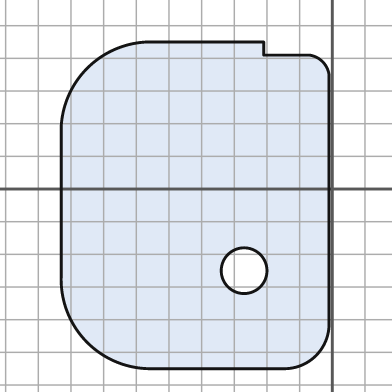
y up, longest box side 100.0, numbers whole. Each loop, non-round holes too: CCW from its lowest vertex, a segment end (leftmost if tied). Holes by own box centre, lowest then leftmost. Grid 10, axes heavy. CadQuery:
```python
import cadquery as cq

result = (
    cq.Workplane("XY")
    .moveTo(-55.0, -55.0)
    .lineTo(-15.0, -55.0)
    .threePointArc((-5.0, -51.0), (-1.0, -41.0))
    .lineTo(-1.0, 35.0)
    .threePointArc((-3.0, 39.0), (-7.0, 41.0))
    .lineTo(-21.0, 41.0)
    .lineTo(-21.0, 45.0)
    .lineTo(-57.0, 45.0)
    .threePointArc((-75.0, 37.0), (-83.0, 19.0))
    .lineTo(-83.0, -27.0)
    .threePointArc((-75.0, -47.0), (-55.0, -55.0))
    .close()
    .moveTo(-27.0, -25.0)
    .circle(7.0)
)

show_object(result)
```